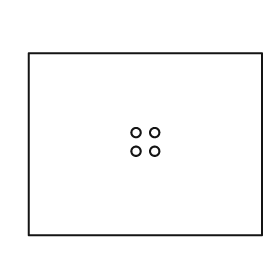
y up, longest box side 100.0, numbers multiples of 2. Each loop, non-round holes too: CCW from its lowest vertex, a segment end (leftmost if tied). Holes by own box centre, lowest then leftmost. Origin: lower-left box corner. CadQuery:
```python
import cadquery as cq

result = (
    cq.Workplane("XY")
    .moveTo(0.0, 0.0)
    .lineTo(100.0, 0.0)
    .lineTo(100.0, 78.0)
    .lineTo(0.0, 78.0)
    .close()
    .moveTo(46.0, 36.0)
    .circle(2.0)
    .moveTo(54.0, 36.0)
    .circle(2.0)
    .moveTo(46.0, 44.0)
    .circle(2.0)
    .moveTo(54.0, 44.0)
    .circle(2.0)
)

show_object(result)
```